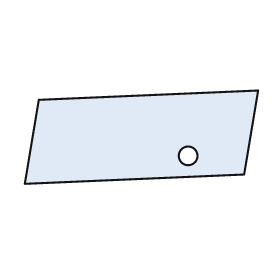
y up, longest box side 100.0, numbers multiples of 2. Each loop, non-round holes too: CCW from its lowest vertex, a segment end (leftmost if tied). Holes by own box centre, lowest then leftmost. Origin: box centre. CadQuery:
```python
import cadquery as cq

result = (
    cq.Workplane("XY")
    .moveTo(-50.0, -20.0)
    .lineTo(44.0, -16.0)
    .lineTo(50.0, 20.0)
    .lineTo(-44.0, 16.0)
    .close()
    .moveTo(20.0, -8.0)
    .circle(4.0)
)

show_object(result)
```